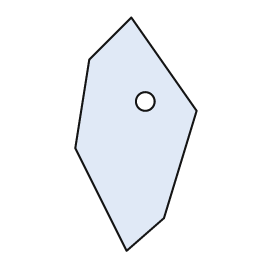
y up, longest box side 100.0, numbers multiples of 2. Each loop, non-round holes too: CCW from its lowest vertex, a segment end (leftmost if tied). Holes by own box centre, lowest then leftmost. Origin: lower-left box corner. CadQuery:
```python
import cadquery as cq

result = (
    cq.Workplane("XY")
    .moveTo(22.0, 0.0)
    .lineTo(38.0, 14.0)
    .lineTo(52.0, 60.0)
    .lineTo(24.0, 100.0)
    .lineTo(6.0, 82.0)
    .lineTo(0.0, 44.0)
    .close()
    .moveTo(30.0, 64.0)
    .circle(4.0)
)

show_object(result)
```